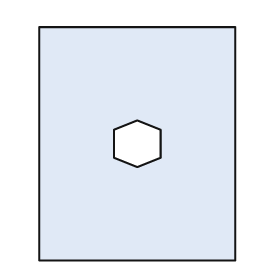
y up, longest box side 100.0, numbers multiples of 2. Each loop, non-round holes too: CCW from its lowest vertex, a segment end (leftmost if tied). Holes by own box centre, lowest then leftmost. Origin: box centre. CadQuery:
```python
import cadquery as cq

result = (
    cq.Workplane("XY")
    .moveTo(-42.0, -50.0)
    .lineTo(42.0, -50.0)
    .lineTo(42.0, 50.0)
    .lineTo(-42.0, 50.0)
    .close()
    .moveTo(0.0, -10.0)
    .lineTo(10.0, -6.0)
    .lineTo(10.0, 6.0)
    .lineTo(0.0, 10.0)
    .lineTo(-10.0, 6.0)
    .lineTo(-10.0, -6.0)
    .close()
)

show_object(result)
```